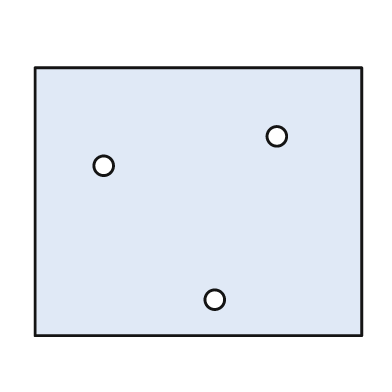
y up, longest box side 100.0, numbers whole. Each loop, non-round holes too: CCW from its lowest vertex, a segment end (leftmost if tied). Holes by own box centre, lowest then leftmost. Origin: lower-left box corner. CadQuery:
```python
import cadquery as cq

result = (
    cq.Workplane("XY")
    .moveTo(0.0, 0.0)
    .lineTo(100.0, 0.0)
    .lineTo(100.0, 82.0)
    .lineTo(0.0, 82.0)
    .close()
    .moveTo(55.0, 11.0)
    .circle(3.0)
    .moveTo(21.0, 52.0)
    .circle(3.0)
    .moveTo(74.0, 61.0)
    .circle(3.0)
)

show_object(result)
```